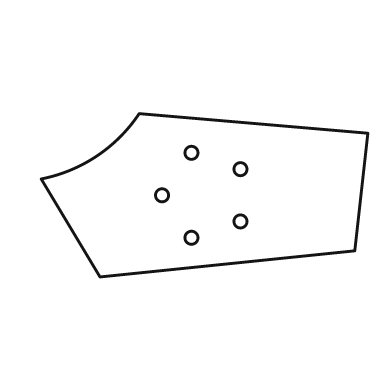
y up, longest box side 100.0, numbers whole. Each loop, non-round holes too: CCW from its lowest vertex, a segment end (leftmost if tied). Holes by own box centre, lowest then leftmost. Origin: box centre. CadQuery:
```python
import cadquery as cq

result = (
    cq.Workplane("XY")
    .moveTo(-32.0, -25.0)
    .lineTo(46.0, -17.0)
    .lineTo(50.0, 19.0)
    .lineTo(-20.0, 25.0)
    .threePointArc((-33.0, 12.0), (-50.0, 5.0))
    .close()
    .moveTo(-4.0, -13.0)
    .circle(2.0)
    .moveTo(11.0, -8.0)
    .circle(2.0)
    .moveTo(-13.0, 0.0)
    .circle(2.0)
    .moveTo(11.0, 8.0)
    .circle(2.0)
    .moveTo(-4.0, 13.0)
    .circle(2.0)
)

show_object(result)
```